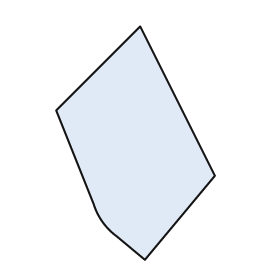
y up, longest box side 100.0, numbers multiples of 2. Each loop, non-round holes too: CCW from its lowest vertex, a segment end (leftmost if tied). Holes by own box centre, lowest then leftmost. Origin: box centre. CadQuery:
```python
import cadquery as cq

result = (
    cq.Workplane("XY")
    .moveTo(4.0, -50.0)
    .lineTo(34.0, -14.0)
    .lineTo(2.0, 50.0)
    .lineTo(-34.0, 14.0)
    .lineTo(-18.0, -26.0)
    .threePointArc((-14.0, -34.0), (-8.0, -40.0))
    .close()
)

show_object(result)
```